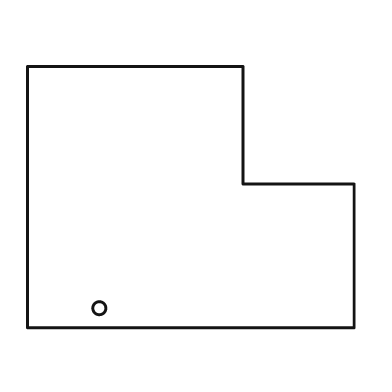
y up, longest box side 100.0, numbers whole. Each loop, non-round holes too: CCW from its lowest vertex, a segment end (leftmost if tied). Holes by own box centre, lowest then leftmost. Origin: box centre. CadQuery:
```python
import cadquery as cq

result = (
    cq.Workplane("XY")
    .moveTo(-50.0, -40.0)
    .lineTo(50.0, -40.0)
    .lineTo(50.0, 4.0)
    .lineTo(16.0, 4.0)
    .lineTo(16.0, 40.0)
    .lineTo(-50.0, 40.0)
    .close()
    .moveTo(-28.0, -34.0)
    .circle(2.0)
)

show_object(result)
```